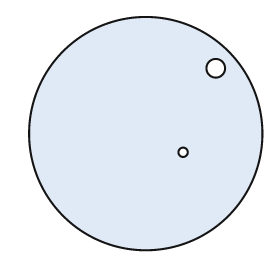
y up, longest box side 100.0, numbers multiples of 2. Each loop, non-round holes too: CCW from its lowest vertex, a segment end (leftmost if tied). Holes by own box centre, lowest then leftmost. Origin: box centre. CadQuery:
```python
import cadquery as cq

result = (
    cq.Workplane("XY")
    .moveTo(0.0, 0.0)
    .circle(50.0)
    .moveTo(16.0, -8.0)
    .circle(2.0)
    .moveTo(30.0, 28.0)
    .circle(4.0)
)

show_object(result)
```